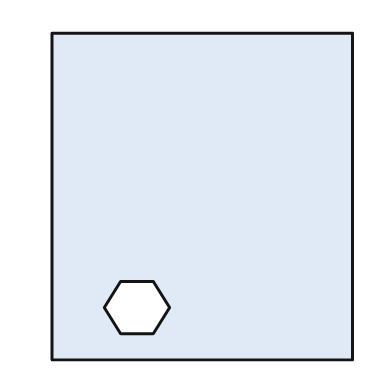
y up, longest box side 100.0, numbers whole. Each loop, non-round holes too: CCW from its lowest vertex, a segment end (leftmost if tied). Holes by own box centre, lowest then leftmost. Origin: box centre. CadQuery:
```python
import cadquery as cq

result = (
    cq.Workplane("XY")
    .moveTo(-46.0, -50.0)
    .lineTo(46.0, -50.0)
    .lineTo(46.0, 50.0)
    .lineTo(-46.0, 50.0)
    .close()
    .moveTo(-25.0, -42.0)
    .lineTo(-15.0, -42.0)
    .lineTo(-10.0, -34.0)
    .lineTo(-15.0, -26.0)
    .lineTo(-25.0, -26.0)
    .lineTo(-30.0, -34.0)
    .close()
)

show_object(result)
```